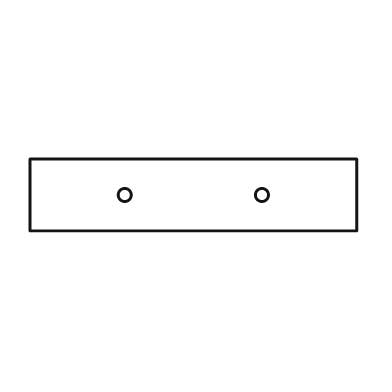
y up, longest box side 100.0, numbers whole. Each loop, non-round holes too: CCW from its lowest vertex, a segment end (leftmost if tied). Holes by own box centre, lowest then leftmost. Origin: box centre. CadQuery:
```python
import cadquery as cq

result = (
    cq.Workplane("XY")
    .moveTo(-50.0, -11.0)
    .lineTo(50.0, -11.0)
    .lineTo(50.0, 11.0)
    .lineTo(-50.0, 11.0)
    .close()
    .moveTo(-21.0, 0.0)
    .circle(2.0)
    .moveTo(21.0, 0.0)
    .circle(2.0)
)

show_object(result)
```